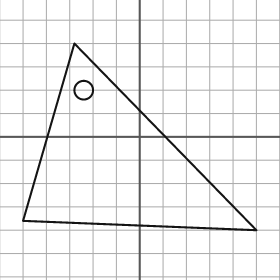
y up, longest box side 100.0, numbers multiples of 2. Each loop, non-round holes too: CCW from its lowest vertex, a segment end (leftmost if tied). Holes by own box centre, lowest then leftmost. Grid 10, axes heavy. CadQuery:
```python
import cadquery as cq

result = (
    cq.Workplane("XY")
    .moveTo(50.0, -40.0)
    .lineTo(-28.0, 40.0)
    .lineTo(-50.0, -36.0)
    .close()
    .moveTo(-24.0, 20.0)
    .circle(4.0)
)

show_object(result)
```